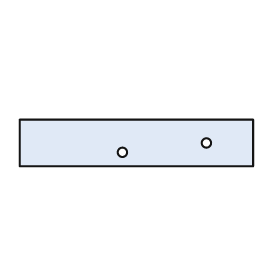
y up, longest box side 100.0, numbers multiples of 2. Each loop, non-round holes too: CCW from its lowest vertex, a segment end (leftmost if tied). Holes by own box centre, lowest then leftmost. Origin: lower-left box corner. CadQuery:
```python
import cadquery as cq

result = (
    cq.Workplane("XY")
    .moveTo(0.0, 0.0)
    .lineTo(100.0, 0.0)
    .lineTo(100.0, 20.0)
    .lineTo(0.0, 20.0)
    .close()
    .moveTo(44.0, 6.0)
    .circle(2.0)
    .moveTo(80.0, 10.0)
    .circle(2.0)
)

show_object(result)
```